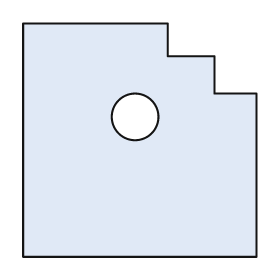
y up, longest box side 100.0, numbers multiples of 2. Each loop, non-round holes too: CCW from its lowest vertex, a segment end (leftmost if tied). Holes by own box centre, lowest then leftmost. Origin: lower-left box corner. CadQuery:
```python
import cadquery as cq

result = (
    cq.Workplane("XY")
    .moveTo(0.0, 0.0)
    .lineTo(100.0, 0.0)
    .lineTo(100.0, 70.0)
    .lineTo(82.0, 70.0)
    .lineTo(82.0, 86.0)
    .lineTo(62.0, 86.0)
    .lineTo(62.0, 100.0)
    .lineTo(0.0, 100.0)
    .close()
    .moveTo(48.0, 60.0)
    .circle(10.0)
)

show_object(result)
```